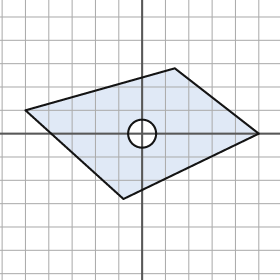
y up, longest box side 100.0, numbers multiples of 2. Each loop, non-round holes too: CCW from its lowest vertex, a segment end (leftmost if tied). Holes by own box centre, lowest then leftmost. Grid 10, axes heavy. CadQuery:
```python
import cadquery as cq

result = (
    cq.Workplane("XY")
    .moveTo(-8.0, -28.0)
    .lineTo(50.0, 0.0)
    .lineTo(14.0, 28.0)
    .lineTo(-50.0, 10.0)
    .close()
    .moveTo(0.0, 0.0)
    .circle(6.0)
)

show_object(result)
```